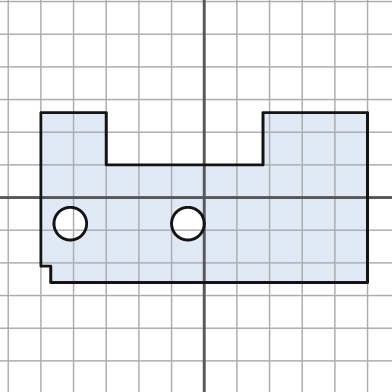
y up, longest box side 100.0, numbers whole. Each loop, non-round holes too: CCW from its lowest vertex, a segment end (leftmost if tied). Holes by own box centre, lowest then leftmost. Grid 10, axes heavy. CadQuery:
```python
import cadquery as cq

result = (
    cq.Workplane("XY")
    .moveTo(-47.0, -26.0)
    .lineTo(50.0, -26.0)
    .lineTo(50.0, 26.0)
    .lineTo(18.0, 26.0)
    .lineTo(18.0, 10.0)
    .lineTo(-30.0, 10.0)
    .lineTo(-30.0, 26.0)
    .lineTo(-50.0, 26.0)
    .lineTo(-50.0, -21.0)
    .lineTo(-47.0, -21.0)
    .close()
    .moveTo(-41.0, -8.0)
    .circle(5.0)
    .moveTo(-5.0, -8.0)
    .circle(5.0)
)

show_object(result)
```